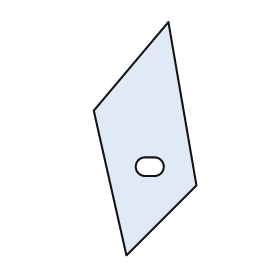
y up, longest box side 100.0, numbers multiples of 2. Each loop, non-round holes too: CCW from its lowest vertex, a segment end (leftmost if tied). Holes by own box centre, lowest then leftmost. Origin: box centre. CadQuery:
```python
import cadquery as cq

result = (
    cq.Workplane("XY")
    .moveTo(-8.0, -50.0)
    .lineTo(22.0, -20.0)
    .lineTo(10.0, 50.0)
    .lineTo(-22.0, 12.0)
    .close()
    .moveTo(0.0, -16.0)
    .lineTo(4.0, -16.0)
    .threePointArc((8.0, -12.0), (4.0, -8.0))
    .lineTo(0.0, -8.0)
    .threePointArc((-4.0, -12.0), (0.0, -16.0))
    .close()
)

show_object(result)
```